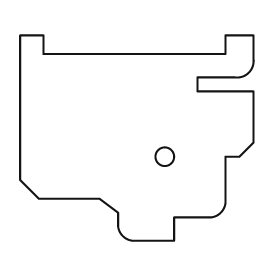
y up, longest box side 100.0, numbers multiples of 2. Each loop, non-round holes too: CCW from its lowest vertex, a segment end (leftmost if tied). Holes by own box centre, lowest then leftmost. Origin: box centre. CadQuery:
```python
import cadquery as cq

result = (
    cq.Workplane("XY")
    .moveTo(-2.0, -44.0)
    .lineTo(16.0, -44.0)
    .lineTo(16.0, -34.0)
    .lineTo(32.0, -34.0)
    .threePointArc((36.0, -32.0), (38.0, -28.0))
    .lineTo(38.0, -8.0)
    .lineTo(44.0, -8.0)
    .lineTo(50.0, -2.0)
    .lineTo(50.0, 20.0)
    .lineTo(26.0, 20.0)
    .lineTo(26.0, 26.0)
    .lineTo(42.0, 26.0)
    .threePointArc((48.0, 28.0), (50.0, 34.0))
    .lineTo(50.0, 44.0)
    .lineTo(38.0, 44.0)
    .lineTo(38.0, 36.0)
    .lineTo(-40.0, 36.0)
    .lineTo(-40.0, 44.0)
    .lineTo(-50.0, 44.0)
    .lineTo(-50.0, -18.0)
    .lineTo(-42.0, -26.0)
    .lineTo(-16.0, -26.0)
    .lineTo(-8.0, -32.0)
    .lineTo(-8.0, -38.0)
    .threePointArc((-6.0, -42.0), (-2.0, -44.0))
    .close()
    .moveTo(12.0, -8.0)
    .circle(4.0)
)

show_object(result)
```